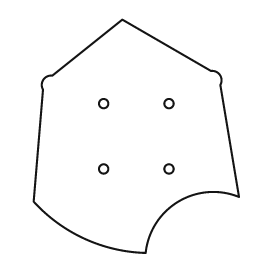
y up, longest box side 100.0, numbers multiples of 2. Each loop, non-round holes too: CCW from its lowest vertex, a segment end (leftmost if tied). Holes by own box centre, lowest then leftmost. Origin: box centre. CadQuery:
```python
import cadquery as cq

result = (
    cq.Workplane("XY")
    .moveTo(4.0, -50.0)
    .threePointArc((18.0, -28.0), (44.0, -26.0))
    .lineTo(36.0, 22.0)
    .threePointArc((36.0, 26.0), (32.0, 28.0))
    .lineTo(-6.0, 50.0)
    .lineTo(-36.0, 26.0)
    .threePointArc((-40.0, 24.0), (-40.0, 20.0))
    .lineTo(-44.0, -28.0)
    .threePointArc((-22.0, -44.0), (4.0, -50.0))
    .close()
    .moveTo(-14.0, -14.0)
    .circle(2.0)
    .moveTo(14.0, -14.0)
    .circle(2.0)
    .moveTo(-14.0, 14.0)
    .circle(2.0)
    .moveTo(14.0, 14.0)
    .circle(2.0)
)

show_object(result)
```